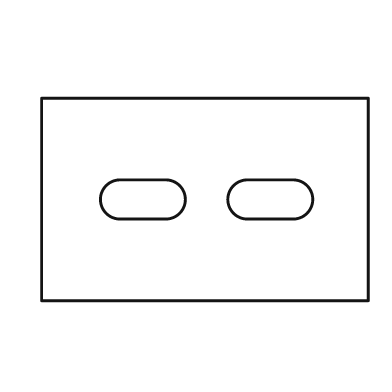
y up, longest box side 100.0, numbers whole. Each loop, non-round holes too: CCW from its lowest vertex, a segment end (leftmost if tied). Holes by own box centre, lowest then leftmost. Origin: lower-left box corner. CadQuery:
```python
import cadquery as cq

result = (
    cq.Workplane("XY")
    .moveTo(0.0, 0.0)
    .lineTo(100.0, 0.0)
    .lineTo(100.0, 62.0)
    .lineTo(0.0, 62.0)
    .close()
    .moveTo(24.0, 25.0)
    .lineTo(38.0, 25.0)
    .threePointArc((44.0, 31.0), (38.0, 37.0))
    .lineTo(24.0, 37.0)
    .threePointArc((18.0, 31.0), (24.0, 25.0))
    .close()
    .moveTo(63.0, 25.0)
    .lineTo(77.0, 25.0)
    .threePointArc((83.0, 31.0), (77.0, 37.0))
    .lineTo(63.0, 37.0)
    .threePointArc((57.0, 31.0), (63.0, 25.0))
    .close()
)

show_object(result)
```